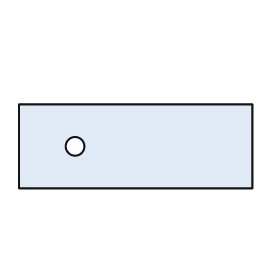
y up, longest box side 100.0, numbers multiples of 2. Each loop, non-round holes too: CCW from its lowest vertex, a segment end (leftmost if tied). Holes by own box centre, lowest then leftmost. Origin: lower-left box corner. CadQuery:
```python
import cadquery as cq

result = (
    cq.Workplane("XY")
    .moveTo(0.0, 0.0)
    .lineTo(100.0, 0.0)
    .lineTo(100.0, 36.0)
    .lineTo(0.0, 36.0)
    .close()
    .moveTo(24.0, 18.0)
    .circle(4.0)
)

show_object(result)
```